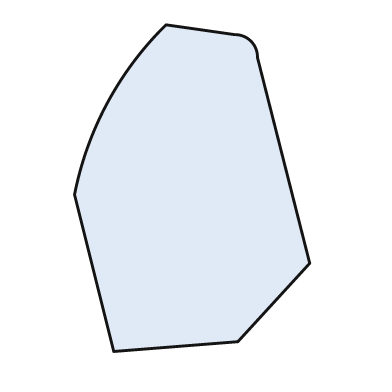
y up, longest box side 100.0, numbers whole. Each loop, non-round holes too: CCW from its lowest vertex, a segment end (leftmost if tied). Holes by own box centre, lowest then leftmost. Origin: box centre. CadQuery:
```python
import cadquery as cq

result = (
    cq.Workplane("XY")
    .moveTo(-24.0, -50.0)
    .lineTo(14.0, -47.0)
    .lineTo(36.0, -23.0)
    .lineTo(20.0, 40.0)
    .threePointArc((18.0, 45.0), (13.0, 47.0))
    .lineTo(-8.0, 50.0)
    .threePointArc((-26.0, 26.0), (-36.0, -2.0))
    .close()
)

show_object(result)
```